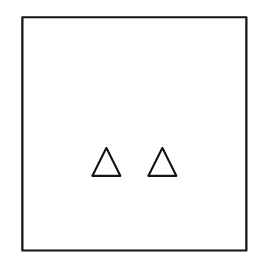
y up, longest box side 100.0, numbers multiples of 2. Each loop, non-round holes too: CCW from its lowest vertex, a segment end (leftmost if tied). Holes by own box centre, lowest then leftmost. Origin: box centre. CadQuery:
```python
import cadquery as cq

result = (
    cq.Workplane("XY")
    .moveTo(-48.0, -50.0)
    .lineTo(48.0, -50.0)
    .lineTo(48.0, 50.0)
    .lineTo(-48.0, 50.0)
    .close()
    .moveTo(-18.0, -18.0)
    .lineTo(-6.0, -18.0)
    .lineTo(-12.0, -6.0)
    .close()
    .moveTo(6.0, -18.0)
    .lineTo(18.0, -18.0)
    .lineTo(12.0, -6.0)
    .close()
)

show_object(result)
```